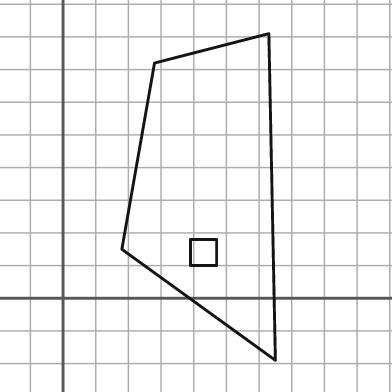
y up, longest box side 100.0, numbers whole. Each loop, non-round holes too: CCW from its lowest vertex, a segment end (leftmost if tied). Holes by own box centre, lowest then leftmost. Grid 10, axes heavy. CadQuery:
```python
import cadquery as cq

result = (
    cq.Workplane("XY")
    .moveTo(65.0, -19.0)
    .lineTo(63.0, 81.0)
    .lineTo(28.0, 72.0)
    .lineTo(18.0, 15.0)
    .close()
    .moveTo(39.0, 10.0)
    .lineTo(47.0, 10.0)
    .lineTo(47.0, 18.0)
    .lineTo(39.0, 18.0)
    .close()
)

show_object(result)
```